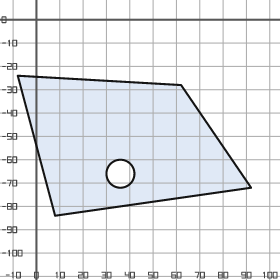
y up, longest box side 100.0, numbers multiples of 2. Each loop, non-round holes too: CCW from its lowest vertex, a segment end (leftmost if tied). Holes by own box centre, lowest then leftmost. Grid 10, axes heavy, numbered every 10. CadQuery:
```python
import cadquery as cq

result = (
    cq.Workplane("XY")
    .moveTo(8.0, -84.0)
    .lineTo(92.0, -72.0)
    .lineTo(62.0, -28.0)
    .lineTo(-8.0, -24.0)
    .close()
    .moveTo(36.0, -66.0)
    .circle(6.0)
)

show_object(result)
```